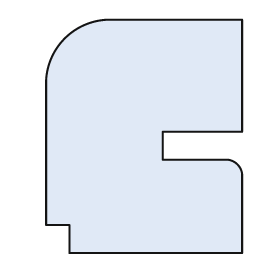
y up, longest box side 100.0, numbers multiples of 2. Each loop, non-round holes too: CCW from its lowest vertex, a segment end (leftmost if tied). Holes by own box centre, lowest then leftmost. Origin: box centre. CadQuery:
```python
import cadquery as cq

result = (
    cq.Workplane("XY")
    .moveTo(-32.0, -50.0)
    .lineTo(42.0, -50.0)
    .lineTo(42.0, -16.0)
    .threePointArc((40.0, -12.0), (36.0, -10.0))
    .lineTo(8.0, -10.0)
    .lineTo(8.0, 2.0)
    .lineTo(42.0, 2.0)
    .lineTo(42.0, 50.0)
    .lineTo(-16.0, 50.0)
    .threePointArc((-34.0, 42.0), (-42.0, 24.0))
    .lineTo(-42.0, -38.0)
    .lineTo(-32.0, -38.0)
    .close()
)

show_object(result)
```